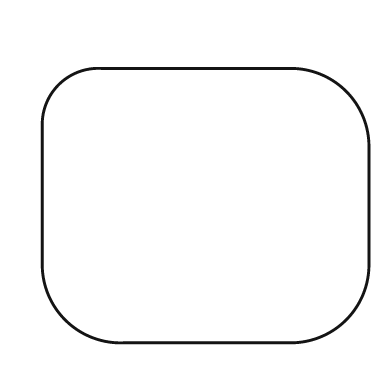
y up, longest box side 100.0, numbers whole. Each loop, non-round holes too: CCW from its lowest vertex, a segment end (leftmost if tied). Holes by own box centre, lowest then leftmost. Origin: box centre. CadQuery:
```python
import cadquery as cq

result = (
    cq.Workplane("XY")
    .moveTo(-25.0, -42.0)
    .lineTo(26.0, -42.0)
    .threePointArc((43.0, -35.0), (50.0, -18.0))
    .lineTo(50.0, 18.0)
    .threePointArc((43.0, 35.0), (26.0, 42.0))
    .lineTo(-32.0, 42.0)
    .threePointArc((-45.0, 37.0), (-50.0, 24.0))
    .lineTo(-50.0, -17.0)
    .threePointArc((-43.0, -35.0), (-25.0, -42.0))
    .close()
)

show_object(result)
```